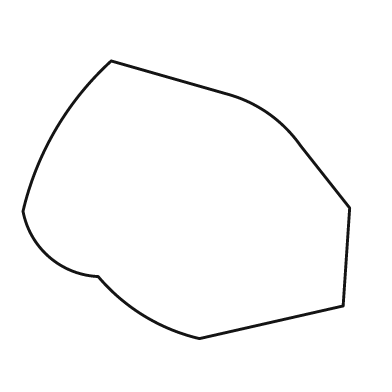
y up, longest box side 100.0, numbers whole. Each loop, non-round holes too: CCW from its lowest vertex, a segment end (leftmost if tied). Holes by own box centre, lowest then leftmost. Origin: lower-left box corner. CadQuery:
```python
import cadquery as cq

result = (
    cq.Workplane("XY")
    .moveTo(54.0, 0.0)
    .lineTo(98.0, 10.0)
    .lineTo(100.0, 40.0)
    .lineTo(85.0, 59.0)
    .threePointArc((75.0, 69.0), (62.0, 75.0))
    .lineTo(27.0, 85.0)
    .threePointArc((10.0, 64.0), (0.0, 39.0))
    .threePointArc((8.0, 25.0), (23.0, 19.0))
    .threePointArc((37.0, 7.0), (54.0, 0.0))
    .close()
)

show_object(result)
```